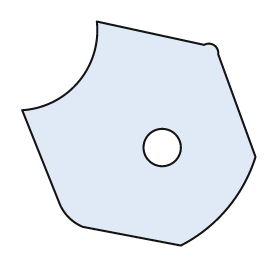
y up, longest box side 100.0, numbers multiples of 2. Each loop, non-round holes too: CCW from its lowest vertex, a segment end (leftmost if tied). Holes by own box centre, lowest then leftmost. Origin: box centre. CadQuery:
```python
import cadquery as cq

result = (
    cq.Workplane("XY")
    .moveTo(18.0, -48.0)
    .threePointArc((38.0, -32.0), (50.0, -10.0))
    .lineTo(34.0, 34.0)
    .threePointArc((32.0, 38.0), (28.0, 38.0))
    .lineTo(-18.0, 48.0)
    .threePointArc((-26.0, 22.0), (-50.0, 10.0))
    .lineTo(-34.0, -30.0)
    .threePointArc((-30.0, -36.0), (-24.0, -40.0))
    .close()
    .moveTo(10.0, -6.0)
    .circle(8.0)
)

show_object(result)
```